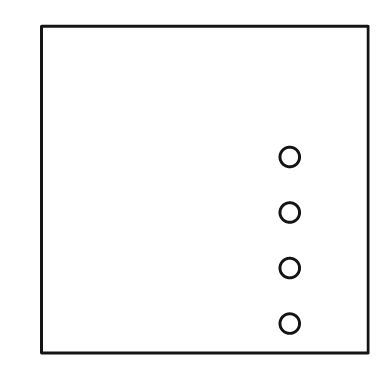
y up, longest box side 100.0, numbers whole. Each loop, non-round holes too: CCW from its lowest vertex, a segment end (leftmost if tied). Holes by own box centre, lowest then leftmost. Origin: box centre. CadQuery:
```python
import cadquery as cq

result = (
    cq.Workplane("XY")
    .moveTo(-50.0, -50.0)
    .lineTo(50.0, -50.0)
    .lineTo(50.0, 50.0)
    .lineTo(-50.0, 50.0)
    .close()
    .moveTo(26.0, -41.0)
    .circle(3.0)
    .moveTo(26.0, -24.0)
    .circle(3.0)
    .moveTo(26.0, -7.0)
    .circle(3.0)
    .moveTo(26.0, 10.0)
    .circle(3.0)
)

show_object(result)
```